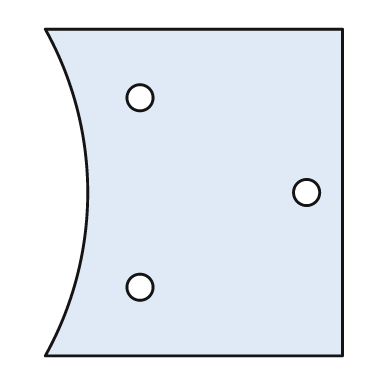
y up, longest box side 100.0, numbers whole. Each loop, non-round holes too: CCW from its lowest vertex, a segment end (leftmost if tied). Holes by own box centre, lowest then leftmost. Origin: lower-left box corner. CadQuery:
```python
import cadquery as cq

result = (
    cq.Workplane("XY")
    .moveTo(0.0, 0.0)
    .lineTo(91.0, 0.0)
    .lineTo(91.0, 100.0)
    .lineTo(0.0, 100.0)
    .threePointArc((13.0, 50.0), (0.0, 0.0))
    .close()
    .moveTo(29.0, 21.0)
    .circle(4.0)
    .moveTo(80.0, 50.0)
    .circle(4.0)
    .moveTo(29.0, 79.0)
    .circle(4.0)
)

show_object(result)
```